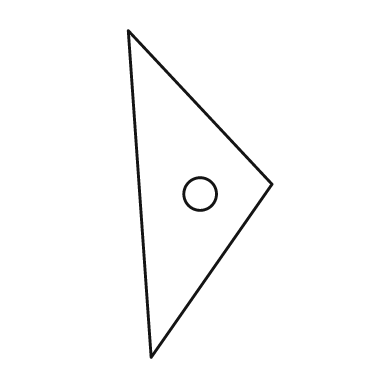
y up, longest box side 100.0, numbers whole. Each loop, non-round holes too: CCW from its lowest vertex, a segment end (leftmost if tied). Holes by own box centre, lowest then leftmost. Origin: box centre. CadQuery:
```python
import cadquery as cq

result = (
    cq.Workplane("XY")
    .moveTo(-15.0, -50.0)
    .lineTo(22.0, 3.0)
    .lineTo(-22.0, 50.0)
    .close()
    .moveTo(0.0, 0.0)
    .circle(5.0)
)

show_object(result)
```